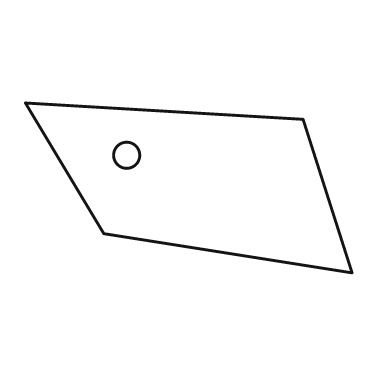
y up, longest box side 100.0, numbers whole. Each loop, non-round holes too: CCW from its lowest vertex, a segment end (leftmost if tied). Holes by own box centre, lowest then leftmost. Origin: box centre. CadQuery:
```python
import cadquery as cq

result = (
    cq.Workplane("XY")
    .moveTo(50.0, -26.0)
    .lineTo(35.0, 21.0)
    .lineTo(-50.0, 26.0)
    .lineTo(-26.0, -14.0)
    .close()
    .moveTo(-19.0, 10.0)
    .circle(4.0)
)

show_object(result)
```